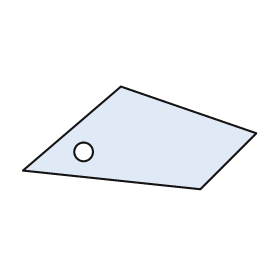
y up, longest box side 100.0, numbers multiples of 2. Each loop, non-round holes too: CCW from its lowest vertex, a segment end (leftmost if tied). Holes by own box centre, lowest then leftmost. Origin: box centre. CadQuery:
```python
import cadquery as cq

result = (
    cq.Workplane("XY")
    .moveTo(26.0, -22.0)
    .lineTo(50.0, 2.0)
    .lineTo(-8.0, 22.0)
    .lineTo(-50.0, -14.0)
    .close()
    .moveTo(-24.0, -6.0)
    .circle(4.0)
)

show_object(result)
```